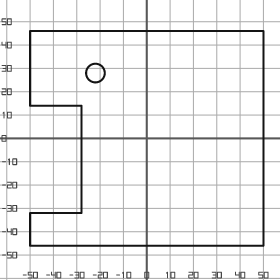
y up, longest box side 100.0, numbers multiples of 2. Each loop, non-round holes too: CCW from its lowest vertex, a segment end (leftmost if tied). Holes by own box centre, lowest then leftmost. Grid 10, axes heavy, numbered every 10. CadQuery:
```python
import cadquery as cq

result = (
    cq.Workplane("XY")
    .moveTo(-50.0, -46.0)
    .lineTo(50.0, -46.0)
    .lineTo(50.0, 46.0)
    .lineTo(-50.0, 46.0)
    .lineTo(-50.0, 14.0)
    .lineTo(-28.0, 14.0)
    .lineTo(-28.0, -32.0)
    .lineTo(-50.0, -32.0)
    .close()
    .moveTo(-22.0, 28.0)
    .circle(4.0)
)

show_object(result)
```